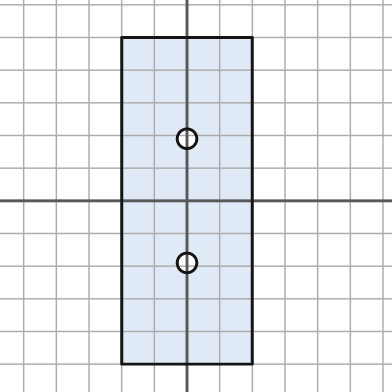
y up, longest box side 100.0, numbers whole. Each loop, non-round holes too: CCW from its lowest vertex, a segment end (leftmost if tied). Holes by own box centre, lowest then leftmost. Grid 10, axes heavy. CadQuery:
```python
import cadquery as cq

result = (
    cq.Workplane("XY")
    .moveTo(-20.0, -50.0)
    .lineTo(20.0, -50.0)
    .lineTo(20.0, 50.0)
    .lineTo(-20.0, 50.0)
    .close()
    .moveTo(0.0, -19.0)
    .circle(3.0)
    .moveTo(0.0, 19.0)
    .circle(3.0)
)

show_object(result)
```